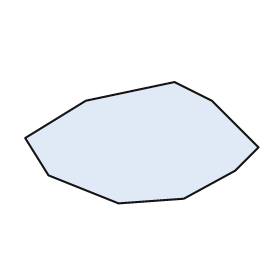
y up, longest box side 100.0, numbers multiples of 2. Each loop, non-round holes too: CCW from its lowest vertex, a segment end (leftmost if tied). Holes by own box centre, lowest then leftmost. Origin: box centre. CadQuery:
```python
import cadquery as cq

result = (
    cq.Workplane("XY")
    .moveTo(-10.0, -26.0)
    .lineTo(18.0, -24.0)
    .lineTo(40.0, -12.0)
    .lineTo(50.0, -2.0)
    .lineTo(30.0, 18.0)
    .lineTo(14.0, 26.0)
    .lineTo(-24.0, 18.0)
    .lineTo(-50.0, 2.0)
    .lineTo(-40.0, -14.0)
    .close()
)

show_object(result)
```